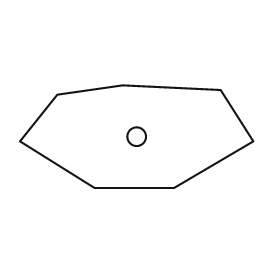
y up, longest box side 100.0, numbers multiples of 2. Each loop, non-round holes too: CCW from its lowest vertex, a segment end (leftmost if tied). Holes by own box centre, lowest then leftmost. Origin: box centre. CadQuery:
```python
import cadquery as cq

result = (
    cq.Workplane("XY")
    .moveTo(-18.0, -22.0)
    .lineTo(16.0, -22.0)
    .lineTo(50.0, -2.0)
    .lineTo(36.0, 20.0)
    .lineTo(-6.0, 22.0)
    .lineTo(-34.0, 18.0)
    .lineTo(-50.0, -2.0)
    .close()
    .moveTo(0.0, 0.0)
    .circle(4.0)
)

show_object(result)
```